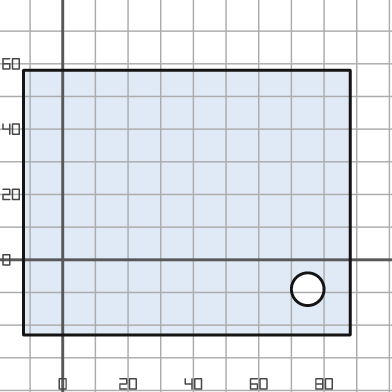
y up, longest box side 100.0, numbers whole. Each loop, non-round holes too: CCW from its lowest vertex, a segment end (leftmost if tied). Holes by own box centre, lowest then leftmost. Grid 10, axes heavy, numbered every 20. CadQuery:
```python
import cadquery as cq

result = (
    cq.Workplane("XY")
    .moveTo(-12.0, -23.0)
    .lineTo(88.0, -23.0)
    .lineTo(88.0, 58.0)
    .lineTo(-12.0, 58.0)
    .close()
    .moveTo(75.0, -9.0)
    .circle(5.0)
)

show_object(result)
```